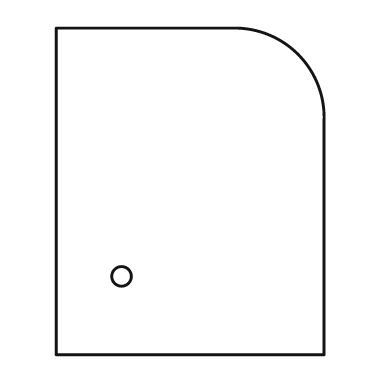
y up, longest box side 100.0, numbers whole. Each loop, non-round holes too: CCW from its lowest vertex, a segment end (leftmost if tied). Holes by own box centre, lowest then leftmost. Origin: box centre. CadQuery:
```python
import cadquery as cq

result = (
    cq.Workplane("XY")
    .moveTo(-41.0, -50.0)
    .lineTo(41.0, -50.0)
    .lineTo(41.0, 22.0)
    .threePointArc((33.0, 42.0), (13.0, 50.0))
    .lineTo(-41.0, 50.0)
    .close()
    .moveTo(-21.0, -26.0)
    .circle(3.0)
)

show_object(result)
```